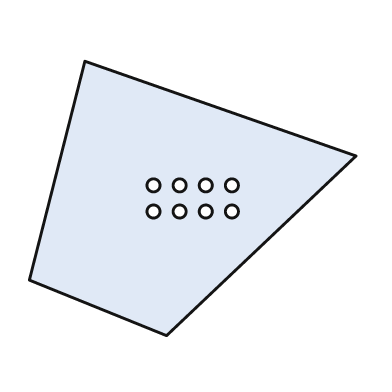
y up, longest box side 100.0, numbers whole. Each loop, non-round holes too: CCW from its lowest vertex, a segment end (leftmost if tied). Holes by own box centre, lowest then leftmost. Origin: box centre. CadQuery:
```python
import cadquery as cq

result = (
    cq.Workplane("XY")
    .moveTo(-8.0, -42.0)
    .lineTo(50.0, 13.0)
    .lineTo(-33.0, 42.0)
    .lineTo(-50.0, -25.0)
    .close()
    .moveTo(-12.0, -4.0)
    .circle(2.0)
    .moveTo(-4.0, -4.0)
    .circle(2.0)
    .moveTo(4.0, -4.0)
    .circle(2.0)
    .moveTo(12.0, -4.0)
    .circle(2.0)
    .moveTo(-12.0, 4.0)
    .circle(2.0)
    .moveTo(-4.0, 4.0)
    .circle(2.0)
    .moveTo(4.0, 4.0)
    .circle(2.0)
    .moveTo(12.0, 4.0)
    .circle(2.0)
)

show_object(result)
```